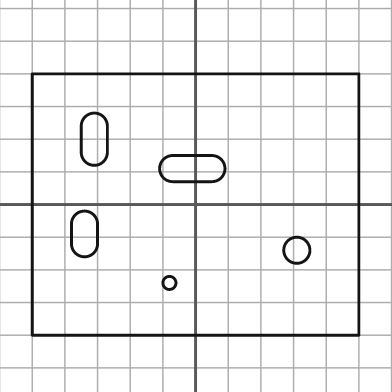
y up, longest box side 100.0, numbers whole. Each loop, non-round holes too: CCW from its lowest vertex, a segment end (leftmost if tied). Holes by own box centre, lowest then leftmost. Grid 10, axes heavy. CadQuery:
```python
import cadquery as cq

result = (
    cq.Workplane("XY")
    .moveTo(-50.0, -40.0)
    .lineTo(50.0, -40.0)
    .lineTo(50.0, 40.0)
    .lineTo(-50.0, 40.0)
    .close()
    .moveTo(-8.0, -24.0)
    .circle(2.0)
    .moveTo(31.0, -14.0)
    .circle(4.0)
    .moveTo(-38.0, -12.0)
    .threePointArc((-34.0, -16.0), (-30.0, -12.0))
    .lineTo(-30.0, -6.0)
    .threePointArc((-34.0, -2.0), (-38.0, -6.0))
    .close()
    .moveTo(-7.0, 7.0)
    .lineTo(5.0, 7.0)
    .threePointArc((9.0, 11.0), (5.0, 15.0))
    .lineTo(-7.0, 15.0)
    .threePointArc((-11.0, 11.0), (-7.0, 7.0))
    .close()
    .moveTo(-35.0, 16.0)
    .threePointArc((-31.0, 12.0), (-27.0, 16.0))
    .lineTo(-27.0, 24.0)
    .threePointArc((-31.0, 28.0), (-35.0, 24.0))
    .close()
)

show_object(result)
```